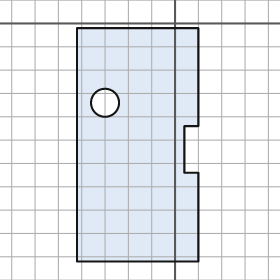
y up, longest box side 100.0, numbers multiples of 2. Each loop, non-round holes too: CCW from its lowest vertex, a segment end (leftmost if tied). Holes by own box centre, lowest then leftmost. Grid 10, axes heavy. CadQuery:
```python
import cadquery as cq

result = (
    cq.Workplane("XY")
    .moveTo(-42.0, -102.0)
    .lineTo(10.0, -102.0)
    .lineTo(10.0, -64.0)
    .lineTo(4.0, -64.0)
    .lineTo(4.0, -44.0)
    .lineTo(10.0, -44.0)
    .lineTo(10.0, -2.0)
    .lineTo(-42.0, -2.0)
    .close()
    .moveTo(-30.0, -34.0)
    .circle(6.0)
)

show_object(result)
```